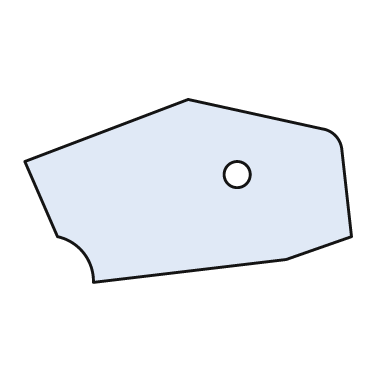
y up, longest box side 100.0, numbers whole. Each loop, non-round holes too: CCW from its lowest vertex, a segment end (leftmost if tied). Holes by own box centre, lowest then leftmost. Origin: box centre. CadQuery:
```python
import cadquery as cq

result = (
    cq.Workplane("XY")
    .moveTo(-29.0, -28.0)
    .lineTo(30.0, -21.0)
    .lineTo(50.0, -14.0)
    .lineTo(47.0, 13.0)
    .threePointArc((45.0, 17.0), (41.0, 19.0))
    .lineTo(0.0, 28.0)
    .lineTo(-50.0, 9.0)
    .lineTo(-40.0, -14.0)
    .threePointArc((-32.0, -19.0), (-29.0, -28.0))
    .close()
    .moveTo(15.0, 5.0)
    .circle(4.0)
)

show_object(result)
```